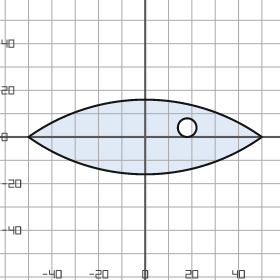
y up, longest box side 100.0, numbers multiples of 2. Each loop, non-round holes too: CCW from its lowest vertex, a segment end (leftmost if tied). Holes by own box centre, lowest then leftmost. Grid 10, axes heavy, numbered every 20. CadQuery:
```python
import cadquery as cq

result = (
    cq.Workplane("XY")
    .moveTo(-50.0, 0.0)
    .threePointArc((0.0, -16.0), (50.0, 0.0))
    .threePointArc((0.0, 16.0), (-50.0, 0.0))
    .close()
    .moveTo(18.0, 4.0)
    .circle(4.0)
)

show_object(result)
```